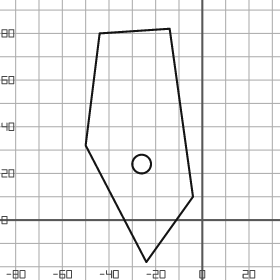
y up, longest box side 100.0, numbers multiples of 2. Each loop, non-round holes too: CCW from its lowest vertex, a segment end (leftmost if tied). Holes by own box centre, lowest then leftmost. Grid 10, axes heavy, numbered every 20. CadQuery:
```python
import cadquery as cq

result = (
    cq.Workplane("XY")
    .moveTo(-24.0, -18.0)
    .lineTo(-4.0, 10.0)
    .lineTo(-14.0, 82.0)
    .lineTo(-44.0, 80.0)
    .lineTo(-50.0, 32.0)
    .close()
    .moveTo(-26.0, 24.0)
    .circle(4.0)
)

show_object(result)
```